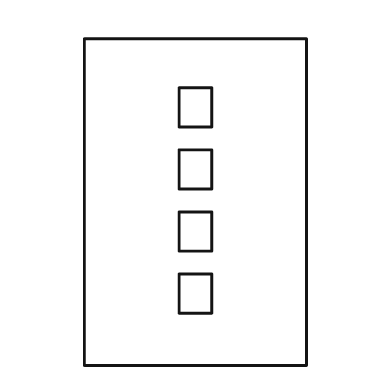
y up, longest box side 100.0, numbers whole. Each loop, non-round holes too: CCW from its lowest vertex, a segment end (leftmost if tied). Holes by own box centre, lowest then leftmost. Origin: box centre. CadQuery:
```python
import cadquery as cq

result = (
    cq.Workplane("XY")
    .moveTo(-34.0, -50.0)
    .lineTo(34.0, -50.0)
    .lineTo(34.0, 50.0)
    .lineTo(-34.0, 50.0)
    .close()
    .moveTo(-5.0, -34.0)
    .lineTo(5.0, -34.0)
    .lineTo(5.0, -22.0)
    .lineTo(-5.0, -22.0)
    .close()
    .moveTo(-5.0, -15.0)
    .lineTo(5.0, -15.0)
    .lineTo(5.0, -3.0)
    .lineTo(-5.0, -3.0)
    .close()
    .moveTo(-5.0, 4.0)
    .lineTo(5.0, 4.0)
    .lineTo(5.0, 16.0)
    .lineTo(-5.0, 16.0)
    .close()
    .moveTo(-5.0, 23.0)
    .lineTo(5.0, 23.0)
    .lineTo(5.0, 35.0)
    .lineTo(-5.0, 35.0)
    .close()
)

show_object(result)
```